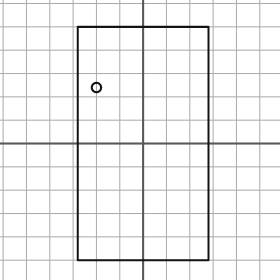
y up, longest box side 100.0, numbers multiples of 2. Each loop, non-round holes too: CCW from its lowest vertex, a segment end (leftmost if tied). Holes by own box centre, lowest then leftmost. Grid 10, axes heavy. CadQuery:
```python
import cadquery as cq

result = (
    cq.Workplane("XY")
    .moveTo(-28.0, -50.0)
    .lineTo(28.0, -50.0)
    .lineTo(28.0, 50.0)
    .lineTo(-28.0, 50.0)
    .close()
    .moveTo(-20.0, 24.0)
    .circle(2.0)
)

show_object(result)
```